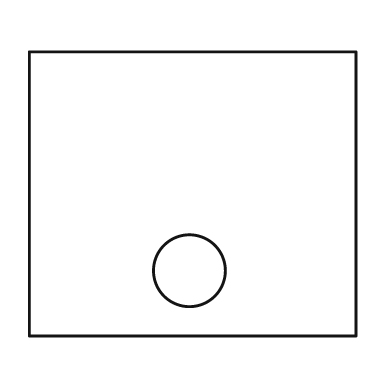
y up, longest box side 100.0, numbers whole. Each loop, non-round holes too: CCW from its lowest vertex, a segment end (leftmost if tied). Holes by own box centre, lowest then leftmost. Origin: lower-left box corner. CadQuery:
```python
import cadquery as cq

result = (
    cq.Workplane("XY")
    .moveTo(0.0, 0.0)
    .lineTo(100.0, 0.0)
    .lineTo(100.0, 87.0)
    .lineTo(0.0, 87.0)
    .close()
    .moveTo(49.0, 20.0)
    .circle(11.0)
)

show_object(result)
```